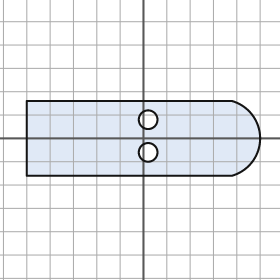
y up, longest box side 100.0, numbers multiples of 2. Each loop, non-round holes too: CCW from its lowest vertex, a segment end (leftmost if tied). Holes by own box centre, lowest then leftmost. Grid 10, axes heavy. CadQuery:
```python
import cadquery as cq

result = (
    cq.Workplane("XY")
    .moveTo(-50.0, -16.0)
    .lineTo(38.0, -16.0)
    .threePointArc((50.0, 0.0), (38.0, 16.0))
    .lineTo(-50.0, 16.0)
    .close()
    .moveTo(2.0, -6.0)
    .circle(4.0)
    .moveTo(2.0, 8.0)
    .circle(4.0)
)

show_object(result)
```